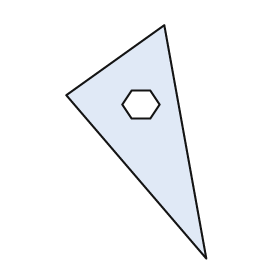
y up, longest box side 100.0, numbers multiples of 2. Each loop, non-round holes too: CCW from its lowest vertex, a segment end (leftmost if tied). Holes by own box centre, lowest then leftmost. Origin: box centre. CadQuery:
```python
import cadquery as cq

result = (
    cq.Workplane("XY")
    .moveTo(30.0, -50.0)
    .lineTo(12.0, 50.0)
    .lineTo(-30.0, 20.0)
    .close()
    .moveTo(-2.0, 10.0)
    .lineTo(6.0, 10.0)
    .lineTo(10.0, 16.0)
    .lineTo(6.0, 22.0)
    .lineTo(-2.0, 22.0)
    .lineTo(-6.0, 16.0)
    .close()
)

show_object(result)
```